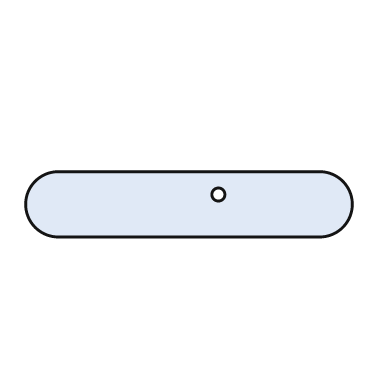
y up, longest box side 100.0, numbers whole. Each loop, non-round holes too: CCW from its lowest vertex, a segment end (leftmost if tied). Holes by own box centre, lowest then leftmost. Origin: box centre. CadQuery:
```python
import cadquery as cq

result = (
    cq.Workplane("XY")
    .moveTo(-40.0, -10.0)
    .lineTo(40.0, -10.0)
    .threePointArc((50.0, 0.0), (40.0, 10.0))
    .lineTo(-40.0, 10.0)
    .threePointArc((-50.0, 0.0), (-40.0, -10.0))
    .close()
    .moveTo(9.0, 3.0)
    .circle(2.0)
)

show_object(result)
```